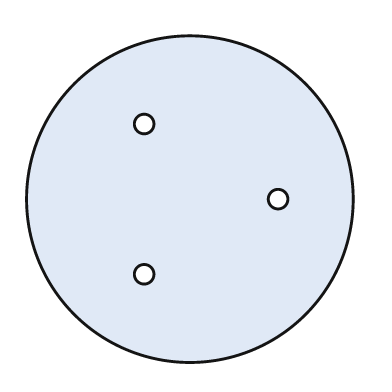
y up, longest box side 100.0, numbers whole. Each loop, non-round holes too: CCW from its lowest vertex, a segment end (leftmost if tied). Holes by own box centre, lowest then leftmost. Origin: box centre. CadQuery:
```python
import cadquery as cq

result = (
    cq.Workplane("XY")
    .moveTo(0.0, 0.0)
    .circle(50.0)
    .moveTo(-14.0, -23.0)
    .circle(3.0)
    .moveTo(27.0, 0.0)
    .circle(3.0)
    .moveTo(-14.0, 23.0)
    .circle(3.0)
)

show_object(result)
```